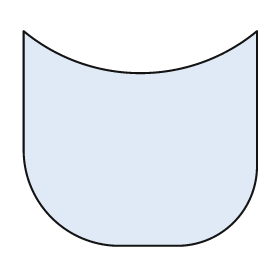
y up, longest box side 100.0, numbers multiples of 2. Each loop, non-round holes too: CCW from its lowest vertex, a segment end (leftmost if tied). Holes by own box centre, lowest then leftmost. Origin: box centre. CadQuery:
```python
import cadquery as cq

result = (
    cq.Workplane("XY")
    .moveTo(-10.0, -46.0)
    .lineTo(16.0, -46.0)
    .threePointArc((40.0, -36.0), (50.0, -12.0))
    .lineTo(50.0, 46.0)
    .threePointArc((0.0, 28.0), (-50.0, 46.0))
    .lineTo(-50.0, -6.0)
    .threePointArc((-38.0, -34.0), (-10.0, -46.0))
    .close()
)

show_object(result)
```